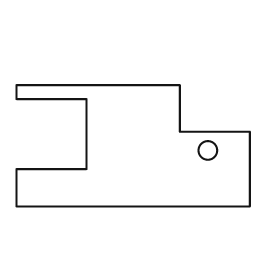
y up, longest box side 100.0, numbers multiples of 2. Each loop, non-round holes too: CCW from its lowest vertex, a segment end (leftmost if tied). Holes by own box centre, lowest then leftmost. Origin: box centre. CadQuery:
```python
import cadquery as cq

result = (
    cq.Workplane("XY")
    .moveTo(-50.0, -26.0)
    .lineTo(50.0, -26.0)
    .lineTo(50.0, 6.0)
    .lineTo(20.0, 6.0)
    .lineTo(20.0, 26.0)
    .lineTo(-50.0, 26.0)
    .lineTo(-50.0, 20.0)
    .lineTo(-20.0, 20.0)
    .lineTo(-20.0, -10.0)
    .lineTo(-50.0, -10.0)
    .close()
    .moveTo(32.0, -2.0)
    .circle(4.0)
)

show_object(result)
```